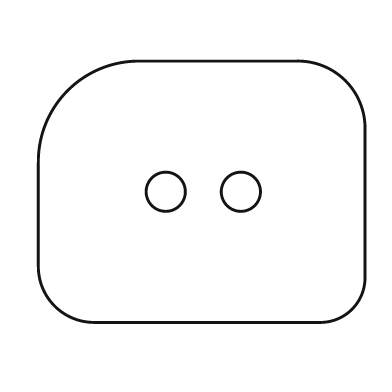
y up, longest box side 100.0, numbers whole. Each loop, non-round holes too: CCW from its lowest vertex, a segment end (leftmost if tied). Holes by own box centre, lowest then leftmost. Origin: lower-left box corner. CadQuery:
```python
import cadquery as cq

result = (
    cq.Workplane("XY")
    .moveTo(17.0, 0.0)
    .lineTo(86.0, 0.0)
    .threePointArc((96.0, 4.0), (100.0, 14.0))
    .lineTo(100.0, 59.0)
    .threePointArc((94.0, 74.0), (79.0, 80.0))
    .lineTo(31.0, 80.0)
    .threePointArc((9.0, 71.0), (0.0, 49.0))
    .lineTo(0.0, 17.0)
    .threePointArc((5.0, 5.0), (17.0, 0.0))
    .close()
    .moveTo(39.0, 40.0)
    .circle(6.0)
    .moveTo(62.0, 40.0)
    .circle(6.0)
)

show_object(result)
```